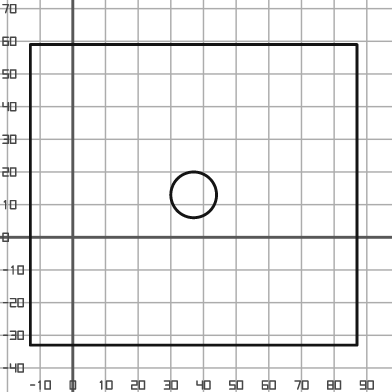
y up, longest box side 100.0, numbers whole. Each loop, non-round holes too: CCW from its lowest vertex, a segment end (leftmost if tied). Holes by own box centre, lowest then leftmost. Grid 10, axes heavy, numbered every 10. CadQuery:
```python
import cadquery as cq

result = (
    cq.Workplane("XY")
    .moveTo(-13.0, -33.0)
    .lineTo(87.0, -33.0)
    .lineTo(87.0, 59.0)
    .lineTo(-13.0, 59.0)
    .close()
    .moveTo(37.0, 13.0)
    .circle(7.0)
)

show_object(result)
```